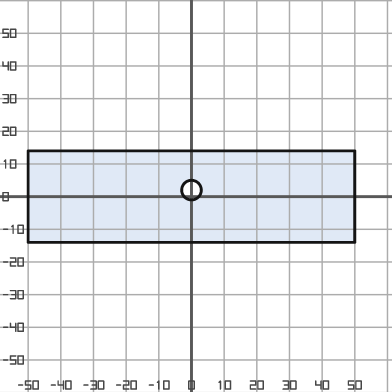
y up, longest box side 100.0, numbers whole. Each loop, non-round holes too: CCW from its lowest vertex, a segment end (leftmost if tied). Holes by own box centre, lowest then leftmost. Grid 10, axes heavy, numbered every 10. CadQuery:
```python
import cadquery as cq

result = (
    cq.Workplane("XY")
    .moveTo(-50.0, -14.0)
    .lineTo(50.0, -14.0)
    .lineTo(50.0, 14.0)
    .lineTo(-50.0, 14.0)
    .close()
    .moveTo(0.0, 2.0)
    .circle(3.0)
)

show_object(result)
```